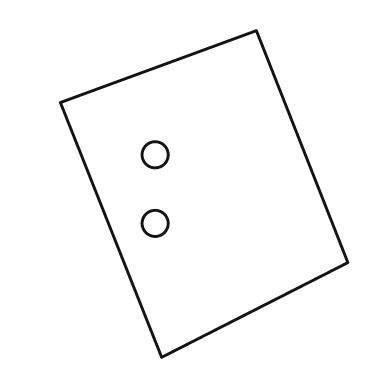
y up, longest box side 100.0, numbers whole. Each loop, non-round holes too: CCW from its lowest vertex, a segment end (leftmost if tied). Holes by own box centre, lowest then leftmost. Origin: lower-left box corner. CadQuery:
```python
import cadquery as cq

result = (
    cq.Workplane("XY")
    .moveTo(31.0, 0.0)
    .lineTo(88.0, 29.0)
    .lineTo(60.0, 100.0)
    .lineTo(0.0, 78.0)
    .close()
    .moveTo(29.0, 41.0)
    .circle(4.0)
    .moveTo(29.0, 62.0)
    .circle(4.0)
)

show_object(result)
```